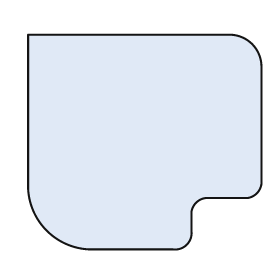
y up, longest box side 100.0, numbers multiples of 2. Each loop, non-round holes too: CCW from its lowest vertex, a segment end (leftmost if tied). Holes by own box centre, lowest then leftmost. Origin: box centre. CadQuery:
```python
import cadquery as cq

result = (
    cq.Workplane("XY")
    .moveTo(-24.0, -46.0)
    .lineTo(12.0, -46.0)
    .threePointArc((18.0, -44.0), (20.0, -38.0))
    .lineTo(20.0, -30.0)
    .threePointArc((22.0, -26.0), (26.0, -24.0))
    .lineTo(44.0, -24.0)
    .threePointArc((48.0, -22.0), (50.0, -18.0))
    .lineTo(50.0, 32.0)
    .threePointArc((46.0, 42.0), (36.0, 46.0))
    .lineTo(-50.0, 46.0)
    .lineTo(-50.0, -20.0)
    .threePointArc((-42.0, -38.0), (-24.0, -46.0))
    .close()
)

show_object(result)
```